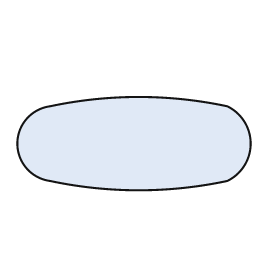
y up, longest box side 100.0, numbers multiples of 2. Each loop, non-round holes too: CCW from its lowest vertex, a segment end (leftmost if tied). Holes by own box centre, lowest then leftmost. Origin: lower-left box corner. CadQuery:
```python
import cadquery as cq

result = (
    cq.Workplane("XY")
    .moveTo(14.0, 4.0)
    .threePointArc((52.0, 0.0), (90.0, 4.0))
    .threePointArc((100.0, 20.0), (90.0, 36.0))
    .threePointArc((52.0, 40.0), (14.0, 36.0))
    .threePointArc((0.0, 20.0), (14.0, 4.0))
    .close()
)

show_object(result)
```